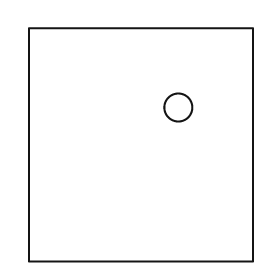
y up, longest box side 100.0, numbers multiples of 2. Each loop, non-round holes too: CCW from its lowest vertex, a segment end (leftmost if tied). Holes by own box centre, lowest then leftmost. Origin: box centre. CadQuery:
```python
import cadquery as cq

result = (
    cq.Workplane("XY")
    .moveTo(-48.0, -50.0)
    .lineTo(48.0, -50.0)
    .lineTo(48.0, 50.0)
    .lineTo(-48.0, 50.0)
    .close()
    .moveTo(16.0, 16.0)
    .circle(6.0)
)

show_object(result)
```